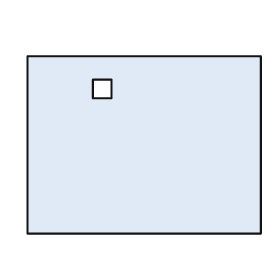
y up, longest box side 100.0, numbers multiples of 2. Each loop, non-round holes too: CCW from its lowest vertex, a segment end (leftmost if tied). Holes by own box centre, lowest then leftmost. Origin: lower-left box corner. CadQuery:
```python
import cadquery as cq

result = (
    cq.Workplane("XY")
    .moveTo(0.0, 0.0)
    .lineTo(100.0, 0.0)
    .lineTo(100.0, 76.0)
    .lineTo(0.0, 76.0)
    .close()
    .moveTo(28.0, 58.0)
    .lineTo(36.0, 58.0)
    .lineTo(36.0, 66.0)
    .lineTo(28.0, 66.0)
    .close()
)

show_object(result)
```